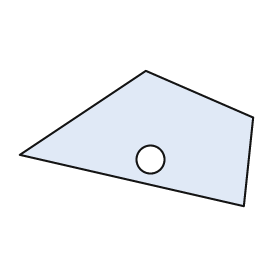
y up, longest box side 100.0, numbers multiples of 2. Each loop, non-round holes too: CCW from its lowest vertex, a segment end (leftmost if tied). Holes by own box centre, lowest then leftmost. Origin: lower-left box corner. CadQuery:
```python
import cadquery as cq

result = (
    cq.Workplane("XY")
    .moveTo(96.0, 0.0)
    .lineTo(100.0, 38.0)
    .lineTo(54.0, 58.0)
    .lineTo(0.0, 22.0)
    .close()
    .moveTo(56.0, 20.0)
    .circle(6.0)
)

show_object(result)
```